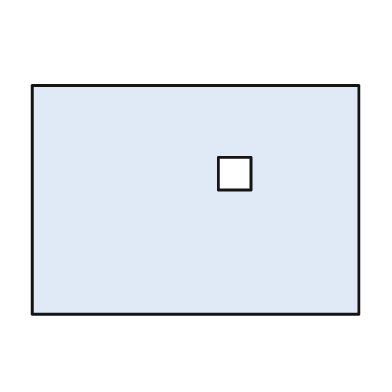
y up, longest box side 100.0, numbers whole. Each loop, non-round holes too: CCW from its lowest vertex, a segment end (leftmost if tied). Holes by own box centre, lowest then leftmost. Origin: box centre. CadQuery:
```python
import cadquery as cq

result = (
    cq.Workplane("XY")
    .moveTo(-50.0, -35.0)
    .lineTo(50.0, -35.0)
    .lineTo(50.0, 35.0)
    .lineTo(-50.0, 35.0)
    .close()
    .moveTo(7.0, 3.0)
    .lineTo(17.0, 3.0)
    .lineTo(17.0, 13.0)
    .lineTo(7.0, 13.0)
    .close()
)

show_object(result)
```